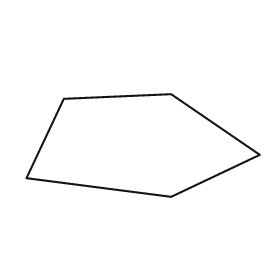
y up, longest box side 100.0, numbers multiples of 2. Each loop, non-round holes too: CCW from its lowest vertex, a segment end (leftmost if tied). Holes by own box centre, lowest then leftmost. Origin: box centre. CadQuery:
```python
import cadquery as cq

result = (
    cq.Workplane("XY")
    .moveTo(12.0, -22.0)
    .lineTo(50.0, -4.0)
    .lineTo(12.0, 22.0)
    .lineTo(-34.0, 20.0)
    .lineTo(-50.0, -14.0)
    .close()
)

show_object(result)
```